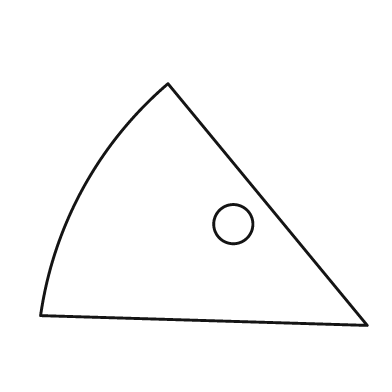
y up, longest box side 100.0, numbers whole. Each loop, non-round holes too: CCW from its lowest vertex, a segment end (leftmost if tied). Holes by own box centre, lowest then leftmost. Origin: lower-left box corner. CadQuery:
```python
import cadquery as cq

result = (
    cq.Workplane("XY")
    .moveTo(100.0, 0.0)
    .lineTo(39.0, 74.0)
    .threePointArc((13.0, 42.0), (0.0, 3.0))
    .close()
    .moveTo(59.0, 31.0)
    .circle(6.0)
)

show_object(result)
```